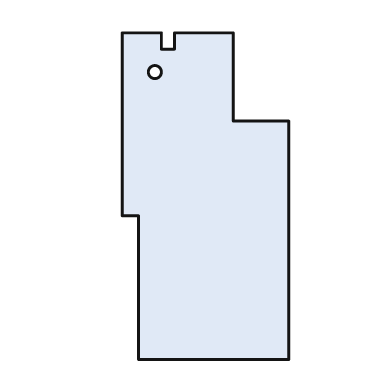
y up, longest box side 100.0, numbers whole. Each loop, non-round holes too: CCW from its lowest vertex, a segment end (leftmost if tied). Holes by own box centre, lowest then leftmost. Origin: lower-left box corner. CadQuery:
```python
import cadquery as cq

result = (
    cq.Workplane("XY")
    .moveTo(5.0, 0.0)
    .lineTo(51.0, 0.0)
    .lineTo(51.0, 73.0)
    .lineTo(34.0, 73.0)
    .lineTo(34.0, 100.0)
    .lineTo(16.0, 100.0)
    .lineTo(16.0, 95.0)
    .lineTo(12.0, 95.0)
    .lineTo(12.0, 100.0)
    .lineTo(0.0, 100.0)
    .lineTo(0.0, 44.0)
    .lineTo(5.0, 44.0)
    .close()
    .moveTo(10.0, 88.0)
    .circle(2.0)
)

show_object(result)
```